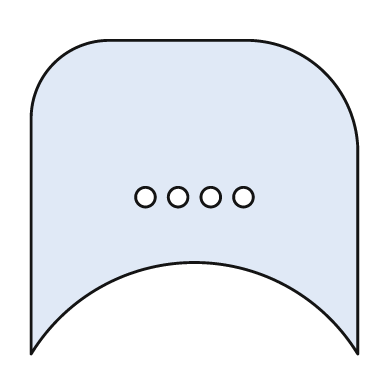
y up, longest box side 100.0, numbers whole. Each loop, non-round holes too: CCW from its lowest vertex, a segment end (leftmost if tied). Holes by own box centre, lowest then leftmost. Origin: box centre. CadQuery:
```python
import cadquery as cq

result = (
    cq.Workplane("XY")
    .moveTo(-50.0, -48.0)
    .threePointArc((0.0, -20.0), (50.0, -48.0))
    .lineTo(50.0, 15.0)
    .threePointArc((40.0, 38.0), (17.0, 48.0))
    .lineTo(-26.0, 48.0)
    .threePointArc((-43.0, 41.0), (-50.0, 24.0))
    .close()
    .moveTo(-15.0, 0.0)
    .circle(3.0)
    .moveTo(-5.0, 0.0)
    .circle(3.0)
    .moveTo(5.0, 0.0)
    .circle(3.0)
    .moveTo(15.0, 0.0)
    .circle(3.0)
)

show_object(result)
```